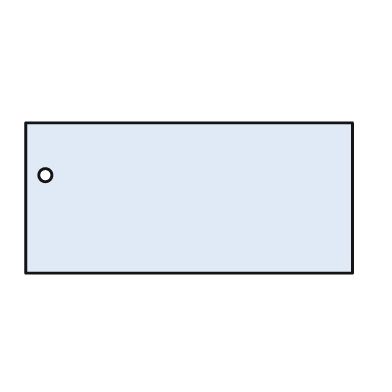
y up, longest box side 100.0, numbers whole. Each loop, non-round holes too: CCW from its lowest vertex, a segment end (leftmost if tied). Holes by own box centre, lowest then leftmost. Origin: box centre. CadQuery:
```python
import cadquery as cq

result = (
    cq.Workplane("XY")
    .moveTo(-50.0, -23.0)
    .lineTo(50.0, -23.0)
    .lineTo(50.0, 23.0)
    .lineTo(-50.0, 23.0)
    .close()
    .moveTo(-44.0, 7.0)
    .circle(2.0)
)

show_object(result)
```